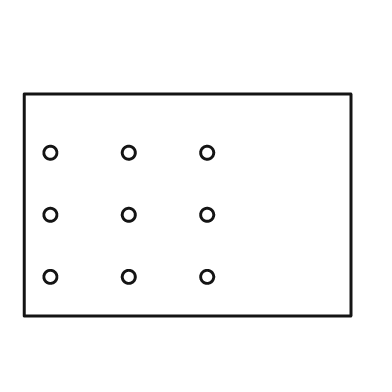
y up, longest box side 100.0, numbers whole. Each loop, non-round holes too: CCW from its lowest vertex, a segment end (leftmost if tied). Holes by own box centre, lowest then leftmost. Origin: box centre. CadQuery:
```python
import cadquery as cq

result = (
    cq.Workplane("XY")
    .moveTo(-50.0, -34.0)
    .lineTo(50.0, -34.0)
    .lineTo(50.0, 34.0)
    .lineTo(-50.0, 34.0)
    .close()
    .moveTo(-42.0, -22.0)
    .circle(2.0)
    .moveTo(-18.0, -22.0)
    .circle(2.0)
    .moveTo(6.0, -22.0)
    .circle(2.0)
    .moveTo(-42.0, -3.0)
    .circle(2.0)
    .moveTo(-18.0, -3.0)
    .circle(2.0)
    .moveTo(6.0, -3.0)
    .circle(2.0)
    .moveTo(-42.0, 16.0)
    .circle(2.0)
    .moveTo(-18.0, 16.0)
    .circle(2.0)
    .moveTo(6.0, 16.0)
    .circle(2.0)
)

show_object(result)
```